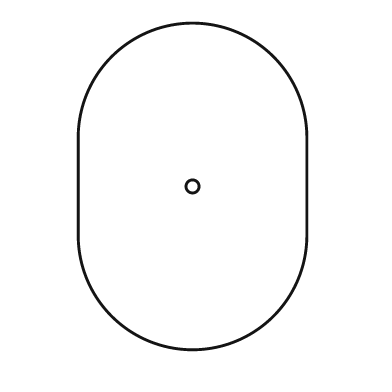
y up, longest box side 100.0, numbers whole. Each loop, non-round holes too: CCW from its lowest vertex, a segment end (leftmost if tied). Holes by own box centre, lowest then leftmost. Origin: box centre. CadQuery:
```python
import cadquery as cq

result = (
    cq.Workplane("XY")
    .moveTo(-35.0, -15.0)
    .threePointArc((0.0, -50.0), (35.0, -15.0))
    .lineTo(35.0, 15.0)
    .threePointArc((0.0, 50.0), (-35.0, 15.0))
    .close()
    .moveTo(0.0, 0.0)
    .circle(2.0)
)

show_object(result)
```